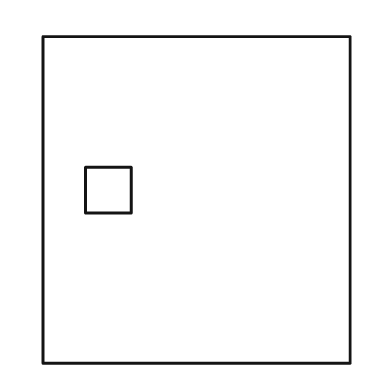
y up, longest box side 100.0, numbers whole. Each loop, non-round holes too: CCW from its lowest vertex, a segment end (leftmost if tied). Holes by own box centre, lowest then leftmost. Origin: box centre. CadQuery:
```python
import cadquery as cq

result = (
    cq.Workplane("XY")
    .moveTo(-47.0, -50.0)
    .lineTo(47.0, -50.0)
    .lineTo(47.0, 50.0)
    .lineTo(-47.0, 50.0)
    .close()
    .moveTo(-34.0, -4.0)
    .lineTo(-20.0, -4.0)
    .lineTo(-20.0, 10.0)
    .lineTo(-34.0, 10.0)
    .close()
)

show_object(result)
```